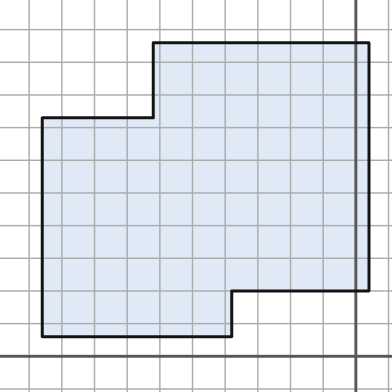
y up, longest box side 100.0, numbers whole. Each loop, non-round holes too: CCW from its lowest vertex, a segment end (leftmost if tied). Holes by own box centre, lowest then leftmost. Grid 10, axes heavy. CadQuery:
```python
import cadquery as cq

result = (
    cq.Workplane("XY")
    .moveTo(-96.0, 6.0)
    .lineTo(-38.0, 6.0)
    .lineTo(-38.0, 20.0)
    .lineTo(4.0, 20.0)
    .lineTo(4.0, 96.0)
    .lineTo(-62.0, 96.0)
    .lineTo(-62.0, 73.0)
    .lineTo(-96.0, 73.0)
    .close()
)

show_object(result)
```